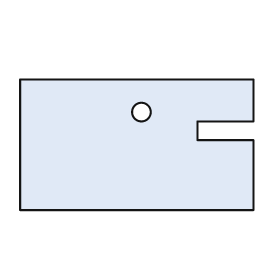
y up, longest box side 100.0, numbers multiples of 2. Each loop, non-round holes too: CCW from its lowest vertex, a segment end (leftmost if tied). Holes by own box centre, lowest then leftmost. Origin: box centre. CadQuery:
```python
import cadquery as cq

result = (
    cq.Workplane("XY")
    .moveTo(-50.0, -28.0)
    .lineTo(50.0, -28.0)
    .lineTo(50.0, 2.0)
    .lineTo(26.0, 2.0)
    .lineTo(26.0, 10.0)
    .lineTo(50.0, 10.0)
    .lineTo(50.0, 28.0)
    .lineTo(-50.0, 28.0)
    .close()
    .moveTo(2.0, 14.0)
    .circle(4.0)
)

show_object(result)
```